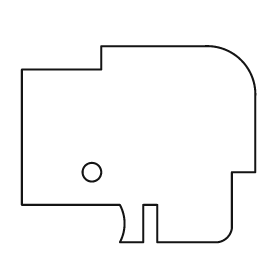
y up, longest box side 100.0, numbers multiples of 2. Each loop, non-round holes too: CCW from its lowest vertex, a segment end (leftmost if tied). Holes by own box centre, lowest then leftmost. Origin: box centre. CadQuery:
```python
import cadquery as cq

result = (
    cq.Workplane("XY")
    .moveTo(-8.0, -42.0)
    .lineTo(2.0, -42.0)
    .lineTo(2.0, -26.0)
    .lineTo(8.0, -26.0)
    .lineTo(8.0, -42.0)
    .lineTo(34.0, -42.0)
    .threePointArc((38.0, -40.0), (40.0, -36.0))
    .lineTo(40.0, -12.0)
    .lineTo(50.0, -12.0)
    .lineTo(50.0, 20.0)
    .threePointArc((44.0, 36.0), (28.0, 42.0))
    .lineTo(-16.0, 42.0)
    .lineTo(-16.0, 32.0)
    .lineTo(-50.0, 32.0)
    .lineTo(-50.0, -26.0)
    .lineTo(-8.0, -26.0)
    .threePointArc((-6.0, -34.0), (-8.0, -42.0))
    .close()
    .moveTo(-20.0, -12.0)
    .circle(4.0)
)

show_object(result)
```